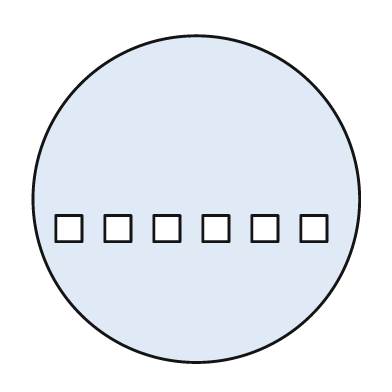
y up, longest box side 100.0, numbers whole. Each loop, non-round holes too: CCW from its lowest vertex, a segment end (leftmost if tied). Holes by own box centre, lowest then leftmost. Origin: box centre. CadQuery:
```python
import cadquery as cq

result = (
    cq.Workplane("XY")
    .moveTo(0.0, 0.0)
    .circle(50.0)
    .moveTo(-43.0, -13.0)
    .lineTo(-35.0, -13.0)
    .lineTo(-35.0, -5.0)
    .lineTo(-43.0, -5.0)
    .close()
    .moveTo(-28.0, -13.0)
    .lineTo(-20.0, -13.0)
    .lineTo(-20.0, -5.0)
    .lineTo(-28.0, -5.0)
    .close()
    .moveTo(-13.0, -13.0)
    .lineTo(-5.0, -13.0)
    .lineTo(-5.0, -5.0)
    .lineTo(-13.0, -5.0)
    .close()
    .moveTo(2.0, -13.0)
    .lineTo(10.0, -13.0)
    .lineTo(10.0, -5.0)
    .lineTo(2.0, -5.0)
    .close()
    .moveTo(17.0, -13.0)
    .lineTo(25.0, -13.0)
    .lineTo(25.0, -5.0)
    .lineTo(17.0, -5.0)
    .close()
    .moveTo(32.0, -13.0)
    .lineTo(40.0, -13.0)
    .lineTo(40.0, -5.0)
    .lineTo(32.0, -5.0)
    .close()
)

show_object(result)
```